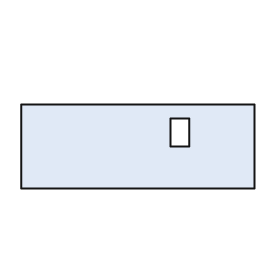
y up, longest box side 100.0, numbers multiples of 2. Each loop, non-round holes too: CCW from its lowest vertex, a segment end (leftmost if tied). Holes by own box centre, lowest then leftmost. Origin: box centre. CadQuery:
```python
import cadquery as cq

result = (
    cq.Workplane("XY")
    .moveTo(-50.0, -18.0)
    .lineTo(50.0, -18.0)
    .lineTo(50.0, 18.0)
    .lineTo(-50.0, 18.0)
    .close()
    .moveTo(14.0, 0.0)
    .lineTo(22.0, 0.0)
    .lineTo(22.0, 12.0)
    .lineTo(14.0, 12.0)
    .close()
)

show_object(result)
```